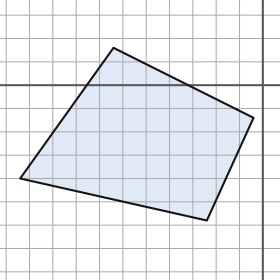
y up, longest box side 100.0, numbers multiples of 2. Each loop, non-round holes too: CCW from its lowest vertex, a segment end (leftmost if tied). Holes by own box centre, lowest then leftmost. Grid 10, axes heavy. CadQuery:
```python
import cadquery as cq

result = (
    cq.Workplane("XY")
    .moveTo(-24.0, -58.0)
    .lineTo(-4.0, -14.0)
    .lineTo(-64.0, 16.0)
    .lineTo(-104.0, -40.0)
    .close()
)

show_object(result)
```